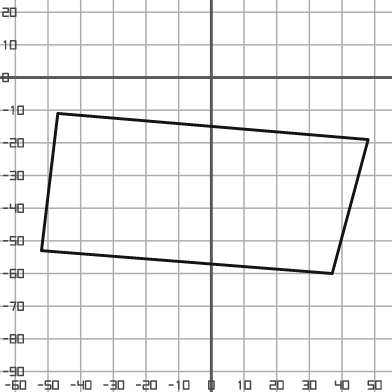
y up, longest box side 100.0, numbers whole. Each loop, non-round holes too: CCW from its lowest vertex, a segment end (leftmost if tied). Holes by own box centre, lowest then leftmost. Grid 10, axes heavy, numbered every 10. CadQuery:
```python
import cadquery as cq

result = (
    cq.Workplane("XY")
    .moveTo(37.0, -60.0)
    .lineTo(48.0, -19.0)
    .lineTo(-47.0, -11.0)
    .lineTo(-52.0, -53.0)
    .close()
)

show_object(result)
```